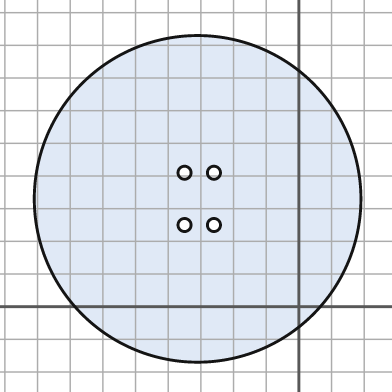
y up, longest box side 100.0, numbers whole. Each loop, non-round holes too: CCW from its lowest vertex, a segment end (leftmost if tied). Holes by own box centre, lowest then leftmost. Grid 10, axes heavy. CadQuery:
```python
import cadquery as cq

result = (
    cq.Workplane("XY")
    .moveTo(-31.0, 33.0)
    .circle(50.0)
    .moveTo(-35.0, 25.0)
    .circle(2.0)
    .moveTo(-26.0, 25.0)
    .circle(2.0)
    .moveTo(-35.0, 41.0)
    .circle(2.0)
    .moveTo(-26.0, 41.0)
    .circle(2.0)
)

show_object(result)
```